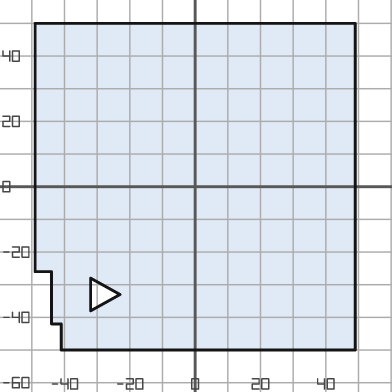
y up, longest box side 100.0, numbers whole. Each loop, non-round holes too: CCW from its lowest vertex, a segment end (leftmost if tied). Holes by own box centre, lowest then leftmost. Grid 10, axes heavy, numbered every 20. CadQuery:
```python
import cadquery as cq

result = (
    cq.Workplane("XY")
    .moveTo(-41.0, -50.0)
    .lineTo(49.0, -50.0)
    .lineTo(49.0, 50.0)
    .lineTo(-49.0, 50.0)
    .lineTo(-49.0, -26.0)
    .lineTo(-44.0, -26.0)
    .lineTo(-44.0, -42.0)
    .lineTo(-41.0, -42.0)
    .close()
    .moveTo(-32.0, -38.0)
    .lineTo(-23.0, -33.0)
    .lineTo(-32.0, -28.0)
    .close()
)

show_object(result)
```